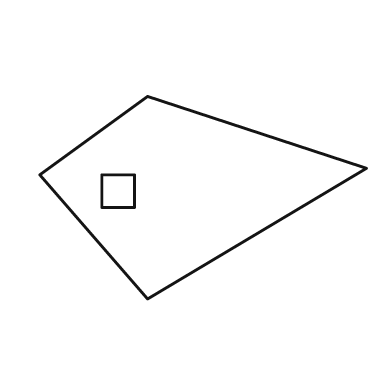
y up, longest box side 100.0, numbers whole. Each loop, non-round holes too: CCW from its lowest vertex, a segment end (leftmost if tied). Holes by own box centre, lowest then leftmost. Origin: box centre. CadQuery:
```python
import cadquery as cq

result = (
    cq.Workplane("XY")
    .moveTo(-17.0, -31.0)
    .lineTo(50.0, 9.0)
    .lineTo(-17.0, 31.0)
    .lineTo(-50.0, 7.0)
    .close()
    .moveTo(-31.0, -3.0)
    .lineTo(-21.0, -3.0)
    .lineTo(-21.0, 7.0)
    .lineTo(-31.0, 7.0)
    .close()
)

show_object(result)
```